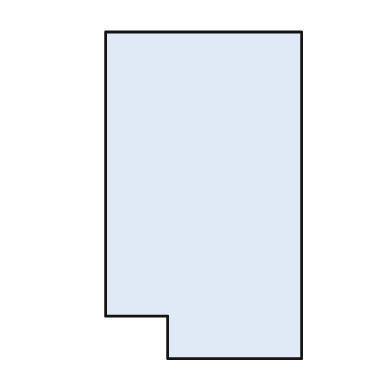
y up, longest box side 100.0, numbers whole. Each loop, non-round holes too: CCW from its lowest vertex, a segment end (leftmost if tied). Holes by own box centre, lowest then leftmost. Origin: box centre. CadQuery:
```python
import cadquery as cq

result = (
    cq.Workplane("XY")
    .moveTo(-11.0, -50.0)
    .lineTo(30.0, -50.0)
    .lineTo(30.0, 50.0)
    .lineTo(-30.0, 50.0)
    .lineTo(-30.0, -37.0)
    .lineTo(-11.0, -37.0)
    .close()
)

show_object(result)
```